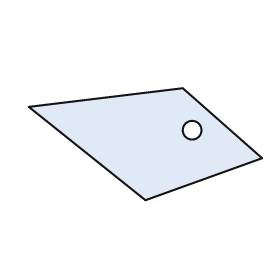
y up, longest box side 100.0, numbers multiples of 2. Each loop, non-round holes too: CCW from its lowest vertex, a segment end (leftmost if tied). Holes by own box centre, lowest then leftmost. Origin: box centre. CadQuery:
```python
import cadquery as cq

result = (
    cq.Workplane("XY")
    .moveTo(0.0, -24.0)
    .lineTo(50.0, -6.0)
    .lineTo(16.0, 24.0)
    .lineTo(-50.0, 16.0)
    .close()
    .moveTo(20.0, 6.0)
    .circle(4.0)
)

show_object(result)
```